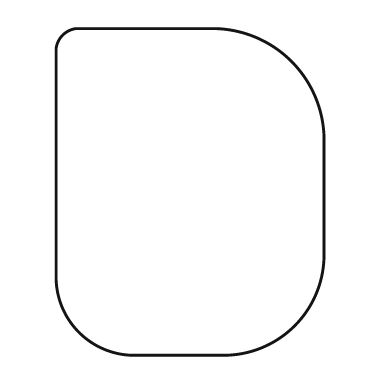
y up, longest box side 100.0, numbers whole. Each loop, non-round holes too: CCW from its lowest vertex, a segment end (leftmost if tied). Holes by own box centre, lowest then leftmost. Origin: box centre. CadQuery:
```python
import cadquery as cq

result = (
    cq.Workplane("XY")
    .moveTo(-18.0, -50.0)
    .lineTo(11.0, -50.0)
    .threePointArc((32.0, -41.0), (41.0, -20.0))
    .lineTo(41.0, 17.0)
    .threePointArc((31.0, 40.0), (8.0, 50.0))
    .lineTo(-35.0, 50.0)
    .threePointArc((-39.0, 48.0), (-41.0, 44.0))
    .lineTo(-41.0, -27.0)
    .threePointArc((-34.0, -43.0), (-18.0, -50.0))
    .close()
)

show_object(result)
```